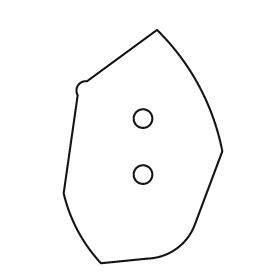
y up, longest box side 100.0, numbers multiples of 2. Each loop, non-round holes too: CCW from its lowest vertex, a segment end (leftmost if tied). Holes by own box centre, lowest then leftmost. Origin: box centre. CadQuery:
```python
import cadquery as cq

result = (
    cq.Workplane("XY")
    .moveTo(-18.0, -50.0)
    .lineTo(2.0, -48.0)
    .threePointArc((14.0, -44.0), (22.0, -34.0))
    .lineTo(34.0, -2.0)
    .threePointArc((24.0, 26.0), (6.0, 50.0))
    .lineTo(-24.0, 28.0)
    .threePointArc((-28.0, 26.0), (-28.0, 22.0))
    .lineTo(-34.0, -20.0)
    .threePointArc((-28.0, -36.0), (-18.0, -50.0))
    .close()
    .moveTo(0.0, -12.0)
    .circle(4.0)
    .moveTo(0.0, 12.0)
    .circle(4.0)
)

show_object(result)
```